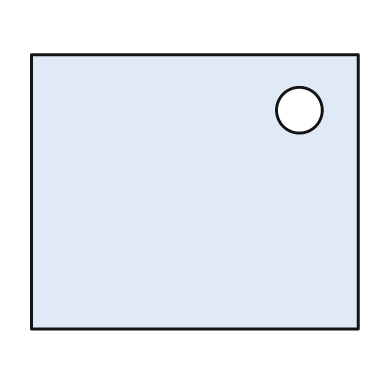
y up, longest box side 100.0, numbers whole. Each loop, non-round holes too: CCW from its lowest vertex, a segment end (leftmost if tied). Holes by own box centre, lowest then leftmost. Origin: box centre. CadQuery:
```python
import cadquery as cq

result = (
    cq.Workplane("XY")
    .moveTo(-50.0, -42.0)
    .lineTo(50.0, -42.0)
    .lineTo(50.0, 42.0)
    .lineTo(-50.0, 42.0)
    .close()
    .moveTo(32.0, 25.0)
    .circle(7.0)
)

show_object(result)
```